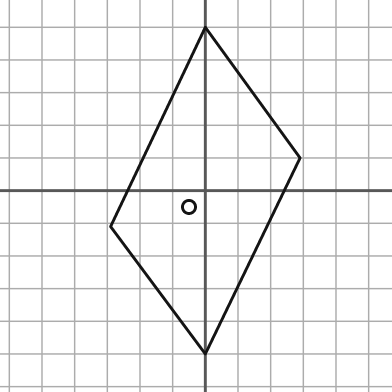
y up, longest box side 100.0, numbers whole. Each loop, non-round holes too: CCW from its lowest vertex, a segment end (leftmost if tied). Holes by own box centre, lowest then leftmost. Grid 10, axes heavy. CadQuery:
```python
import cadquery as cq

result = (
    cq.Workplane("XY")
    .moveTo(0.0, -50.0)
    .lineTo(29.0, 10.0)
    .lineTo(0.0, 50.0)
    .lineTo(-29.0, -11.0)
    .close()
    .moveTo(-5.0, -5.0)
    .circle(2.0)
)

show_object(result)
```